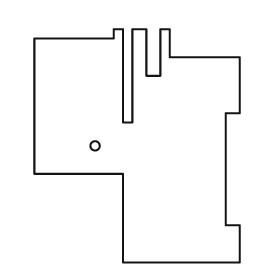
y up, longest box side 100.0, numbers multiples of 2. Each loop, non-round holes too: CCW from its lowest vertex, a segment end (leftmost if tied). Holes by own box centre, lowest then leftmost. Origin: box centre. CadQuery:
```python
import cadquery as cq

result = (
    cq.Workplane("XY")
    .moveTo(-6.0, -50.0)
    .lineTo(44.0, -50.0)
    .lineTo(44.0, -34.0)
    .lineTo(38.0, -34.0)
    .lineTo(38.0, 14.0)
    .lineTo(44.0, 14.0)
    .lineTo(44.0, 38.0)
    .lineTo(14.0, 38.0)
    .lineTo(14.0, 50.0)
    .lineTo(10.0, 50.0)
    .lineTo(10.0, 30.0)
    .lineTo(4.0, 30.0)
    .lineTo(4.0, 50.0)
    .lineTo(-2.0, 50.0)
    .lineTo(-2.0, 10.0)
    .lineTo(-6.0, 10.0)
    .lineTo(-6.0, 50.0)
    .lineTo(-10.0, 50.0)
    .lineTo(-10.0, 46.0)
    .lineTo(-44.0, 46.0)
    .lineTo(-44.0, -12.0)
    .lineTo(-6.0, -12.0)
    .close()
    .moveTo(-18.0, 0.0)
    .circle(2.0)
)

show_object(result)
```